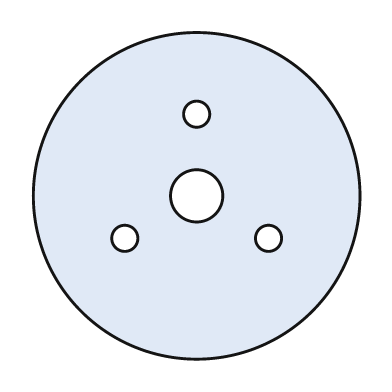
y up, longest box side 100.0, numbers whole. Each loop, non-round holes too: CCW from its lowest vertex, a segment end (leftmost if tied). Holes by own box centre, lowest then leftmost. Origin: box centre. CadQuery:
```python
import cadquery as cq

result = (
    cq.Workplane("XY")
    .moveTo(0.0, 0.0)
    .circle(50.0)
    .moveTo(-22.0, -13.0)
    .circle(4.0)
    .moveTo(22.0, -13.0)
    .circle(4.0)
    .moveTo(0.0, 0.0)
    .circle(8.0)
    .moveTo(0.0, 25.0)
    .circle(4.0)
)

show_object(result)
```